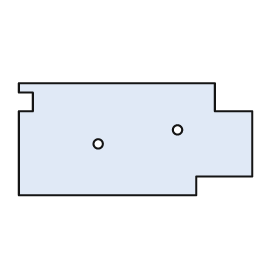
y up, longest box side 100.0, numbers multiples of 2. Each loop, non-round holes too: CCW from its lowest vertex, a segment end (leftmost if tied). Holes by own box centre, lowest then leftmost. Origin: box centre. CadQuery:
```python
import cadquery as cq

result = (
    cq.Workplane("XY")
    .moveTo(-50.0, -24.0)
    .lineTo(26.0, -24.0)
    .lineTo(26.0, -16.0)
    .lineTo(50.0, -16.0)
    .lineTo(50.0, 12.0)
    .lineTo(34.0, 12.0)
    .lineTo(34.0, 24.0)
    .lineTo(-50.0, 24.0)
    .lineTo(-50.0, 20.0)
    .lineTo(-44.0, 20.0)
    .lineTo(-44.0, 12.0)
    .lineTo(-50.0, 12.0)
    .close()
    .moveTo(-16.0, -2.0)
    .circle(2.0)
    .moveTo(18.0, 4.0)
    .circle(2.0)
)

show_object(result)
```